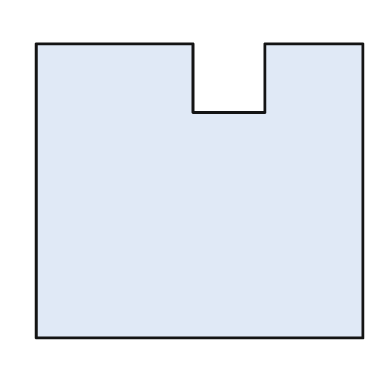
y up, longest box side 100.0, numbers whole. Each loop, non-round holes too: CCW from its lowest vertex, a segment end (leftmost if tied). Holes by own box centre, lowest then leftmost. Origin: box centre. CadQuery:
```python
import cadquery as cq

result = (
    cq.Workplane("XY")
    .moveTo(-50.0, -45.0)
    .lineTo(50.0, -45.0)
    .lineTo(50.0, 45.0)
    .lineTo(20.0, 45.0)
    .lineTo(20.0, 24.0)
    .lineTo(-2.0, 24.0)
    .lineTo(-2.0, 45.0)
    .lineTo(-50.0, 45.0)
    .close()
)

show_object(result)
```